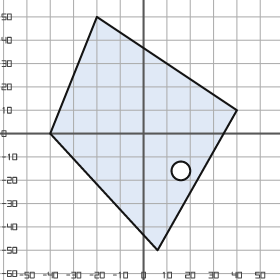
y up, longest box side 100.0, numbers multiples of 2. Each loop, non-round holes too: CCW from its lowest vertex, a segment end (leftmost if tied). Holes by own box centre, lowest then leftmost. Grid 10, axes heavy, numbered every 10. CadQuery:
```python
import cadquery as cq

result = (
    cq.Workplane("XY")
    .moveTo(6.0, -50.0)
    .lineTo(40.0, 10.0)
    .lineTo(-20.0, 50.0)
    .lineTo(-40.0, 0.0)
    .close()
    .moveTo(16.0, -16.0)
    .circle(4.0)
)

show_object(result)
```